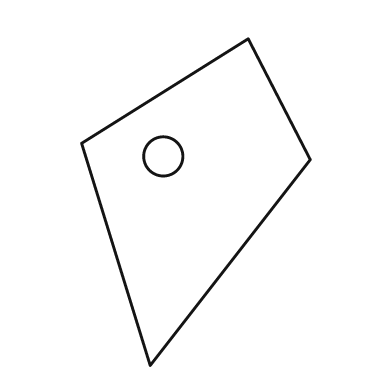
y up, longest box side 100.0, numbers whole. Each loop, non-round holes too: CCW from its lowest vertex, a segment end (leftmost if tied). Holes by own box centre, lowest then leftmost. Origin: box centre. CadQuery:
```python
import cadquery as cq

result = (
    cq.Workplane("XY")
    .moveTo(-14.0, -50.0)
    .lineTo(35.0, 13.0)
    .lineTo(16.0, 50.0)
    .lineTo(-35.0, 18.0)
    .close()
    .moveTo(-10.0, 14.0)
    .circle(6.0)
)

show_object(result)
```